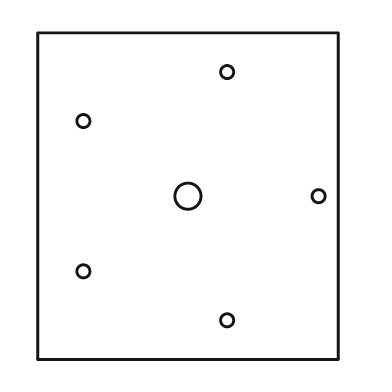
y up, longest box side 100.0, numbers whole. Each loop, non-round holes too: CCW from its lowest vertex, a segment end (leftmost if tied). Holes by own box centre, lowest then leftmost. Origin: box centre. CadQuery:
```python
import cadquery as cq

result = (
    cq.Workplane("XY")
    .moveTo(-46.0, -50.0)
    .lineTo(46.0, -50.0)
    .lineTo(46.0, 50.0)
    .lineTo(-46.0, 50.0)
    .close()
    .moveTo(12.0, -38.0)
    .circle(2.0)
    .moveTo(-32.0, -23.0)
    .circle(2.0)
    .moveTo(0.0, 0.0)
    .circle(4.0)
    .moveTo(40.0, 0.0)
    .circle(2.0)
    .moveTo(-32.0, 23.0)
    .circle(2.0)
    .moveTo(12.0, 38.0)
    .circle(2.0)
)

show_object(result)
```